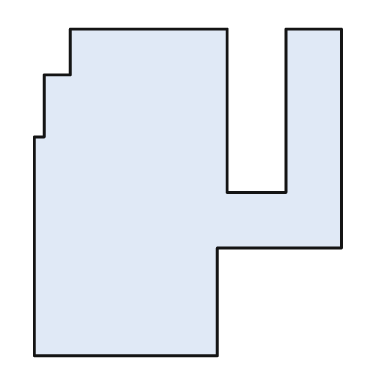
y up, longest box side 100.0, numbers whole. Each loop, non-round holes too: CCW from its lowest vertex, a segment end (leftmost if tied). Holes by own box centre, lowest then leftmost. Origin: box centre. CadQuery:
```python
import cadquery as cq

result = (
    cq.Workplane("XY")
    .moveTo(-47.0, -50.0)
    .lineTo(9.0, -50.0)
    .lineTo(9.0, -17.0)
    .lineTo(47.0, -17.0)
    .lineTo(47.0, 50.0)
    .lineTo(30.0, 50.0)
    .lineTo(30.0, 0.0)
    .lineTo(12.0, 0.0)
    .lineTo(12.0, 50.0)
    .lineTo(-36.0, 50.0)
    .lineTo(-36.0, 36.0)
    .lineTo(-44.0, 36.0)
    .lineTo(-44.0, 17.0)
    .lineTo(-47.0, 17.0)
    .close()
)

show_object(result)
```